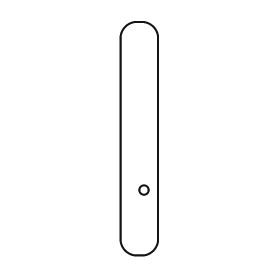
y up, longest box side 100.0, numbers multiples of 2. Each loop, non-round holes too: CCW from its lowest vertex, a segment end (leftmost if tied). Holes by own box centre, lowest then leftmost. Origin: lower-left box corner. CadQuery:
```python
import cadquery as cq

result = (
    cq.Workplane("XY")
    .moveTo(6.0, 0.0)
    .lineTo(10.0, 0.0)
    .threePointArc((14.0, 2.0), (16.0, 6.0))
    .lineTo(16.0, 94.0)
    .threePointArc((14.0, 98.0), (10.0, 100.0))
    .lineTo(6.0, 100.0)
    .threePointArc((2.0, 98.0), (0.0, 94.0))
    .lineTo(0.0, 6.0)
    .threePointArc((2.0, 2.0), (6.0, 0.0))
    .close()
    .moveTo(10.0, 28.0)
    .circle(2.0)
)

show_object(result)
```